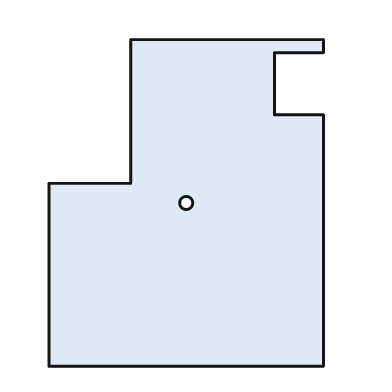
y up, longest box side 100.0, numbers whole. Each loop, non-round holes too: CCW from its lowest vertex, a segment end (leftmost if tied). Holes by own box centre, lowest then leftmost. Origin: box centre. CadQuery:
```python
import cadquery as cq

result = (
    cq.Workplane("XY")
    .moveTo(-42.0, -50.0)
    .lineTo(42.0, -50.0)
    .lineTo(42.0, 27.0)
    .lineTo(27.0, 27.0)
    .lineTo(27.0, 46.0)
    .lineTo(42.0, 46.0)
    .lineTo(42.0, 50.0)
    .lineTo(-17.0, 50.0)
    .lineTo(-17.0, 6.0)
    .lineTo(-42.0, 6.0)
    .close()
    .moveTo(0.0, 0.0)
    .circle(2.0)
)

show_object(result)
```